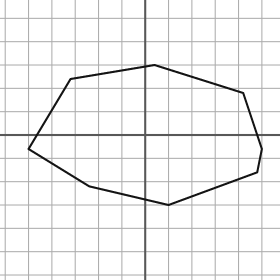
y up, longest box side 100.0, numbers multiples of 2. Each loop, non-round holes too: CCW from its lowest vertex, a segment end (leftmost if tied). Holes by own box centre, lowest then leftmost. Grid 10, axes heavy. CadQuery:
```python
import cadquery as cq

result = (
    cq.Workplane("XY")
    .moveTo(10.0, -30.0)
    .lineTo(48.0, -16.0)
    .lineTo(50.0, -6.0)
    .lineTo(42.0, 18.0)
    .lineTo(4.0, 30.0)
    .lineTo(-32.0, 24.0)
    .lineTo(-50.0, -6.0)
    .lineTo(-24.0, -22.0)
    .close()
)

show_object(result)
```